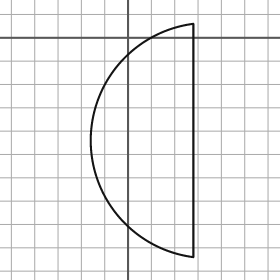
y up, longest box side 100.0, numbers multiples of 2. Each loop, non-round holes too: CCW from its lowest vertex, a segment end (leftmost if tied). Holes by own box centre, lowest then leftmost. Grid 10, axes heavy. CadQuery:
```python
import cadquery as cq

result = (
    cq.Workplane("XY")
    .moveTo(28.0, -94.0)
    .lineTo(28.0, 6.0)
    .threePointArc((-16.0, -44.0), (28.0, -94.0))
    .close()
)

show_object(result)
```